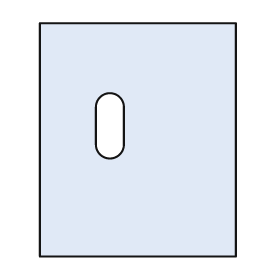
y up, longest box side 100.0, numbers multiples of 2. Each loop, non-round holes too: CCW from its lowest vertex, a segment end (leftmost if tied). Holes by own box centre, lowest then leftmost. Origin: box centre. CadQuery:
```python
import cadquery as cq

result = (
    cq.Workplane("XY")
    .moveTo(-42.0, -50.0)
    .lineTo(42.0, -50.0)
    .lineTo(42.0, 50.0)
    .lineTo(-42.0, 50.0)
    .close()
    .moveTo(-18.0, -2.0)
    .threePointArc((-12.0, -8.0), (-6.0, -2.0))
    .lineTo(-6.0, 14.0)
    .threePointArc((-12.0, 20.0), (-18.0, 14.0))
    .close()
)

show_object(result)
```